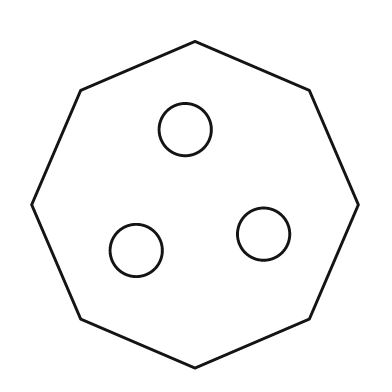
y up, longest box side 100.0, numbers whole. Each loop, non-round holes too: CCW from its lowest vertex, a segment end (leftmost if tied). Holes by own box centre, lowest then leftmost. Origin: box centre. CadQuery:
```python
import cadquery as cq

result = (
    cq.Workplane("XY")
    .moveTo(0.0, -50.0)
    .lineTo(35.0, -35.0)
    .lineTo(50.0, 0.0)
    .lineTo(35.0, 35.0)
    .lineTo(0.0, 50.0)
    .lineTo(-35.0, 35.0)
    .lineTo(-50.0, 0.0)
    .lineTo(-35.0, -35.0)
    .close()
    .moveTo(-18.0, -14.0)
    .circle(8.0)
    .moveTo(21.0, -9.0)
    .circle(8.0)
    .moveTo(-3.0, 23.0)
    .circle(8.0)
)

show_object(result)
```